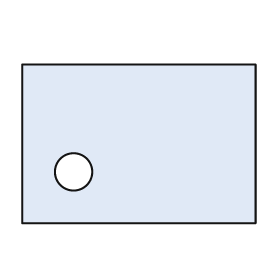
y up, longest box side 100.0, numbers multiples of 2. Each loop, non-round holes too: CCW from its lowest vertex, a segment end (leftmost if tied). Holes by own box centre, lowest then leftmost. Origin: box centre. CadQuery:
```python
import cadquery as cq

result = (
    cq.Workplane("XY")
    .moveTo(-50.0, -34.0)
    .lineTo(50.0, -34.0)
    .lineTo(50.0, 34.0)
    .lineTo(-50.0, 34.0)
    .close()
    .moveTo(-28.0, -12.0)
    .circle(8.0)
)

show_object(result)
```